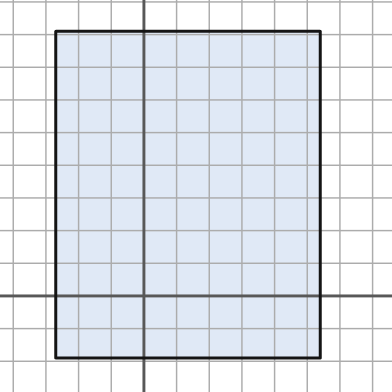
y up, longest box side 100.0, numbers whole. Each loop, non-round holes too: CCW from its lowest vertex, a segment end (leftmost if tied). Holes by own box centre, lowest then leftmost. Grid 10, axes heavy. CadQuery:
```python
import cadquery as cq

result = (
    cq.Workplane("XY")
    .moveTo(-27.0, -19.0)
    .lineTo(54.0, -19.0)
    .lineTo(54.0, 81.0)
    .lineTo(-27.0, 81.0)
    .close()
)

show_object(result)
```